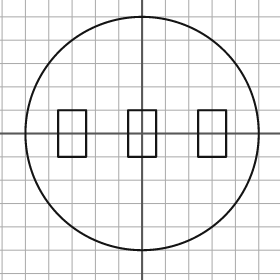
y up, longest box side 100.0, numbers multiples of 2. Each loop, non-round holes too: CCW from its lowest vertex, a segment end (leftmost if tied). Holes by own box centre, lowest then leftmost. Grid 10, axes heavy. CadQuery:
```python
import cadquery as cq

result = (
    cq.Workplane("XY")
    .moveTo(0.0, 0.0)
    .circle(50.0)
    .moveTo(-36.0, -10.0)
    .lineTo(-24.0, -10.0)
    .lineTo(-24.0, 10.0)
    .lineTo(-36.0, 10.0)
    .close()
    .moveTo(-6.0, -10.0)
    .lineTo(6.0, -10.0)
    .lineTo(6.0, 10.0)
    .lineTo(-6.0, 10.0)
    .close()
    .moveTo(24.0, -10.0)
    .lineTo(36.0, -10.0)
    .lineTo(36.0, 10.0)
    .lineTo(24.0, 10.0)
    .close()
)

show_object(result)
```